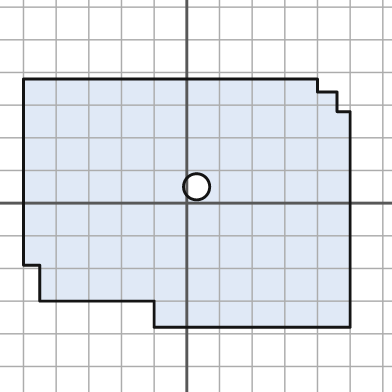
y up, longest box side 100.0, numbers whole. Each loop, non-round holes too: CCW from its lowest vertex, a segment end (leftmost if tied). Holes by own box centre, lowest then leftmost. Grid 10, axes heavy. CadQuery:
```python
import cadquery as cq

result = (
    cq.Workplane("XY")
    .moveTo(-10.0, -38.0)
    .lineTo(50.0, -38.0)
    .lineTo(50.0, 28.0)
    .lineTo(46.0, 28.0)
    .lineTo(46.0, 34.0)
    .lineTo(40.0, 34.0)
    .lineTo(40.0, 38.0)
    .lineTo(-50.0, 38.0)
    .lineTo(-50.0, -19.0)
    .lineTo(-45.0, -19.0)
    .lineTo(-45.0, -30.0)
    .lineTo(-10.0, -30.0)
    .close()
    .moveTo(3.0, 5.0)
    .circle(4.0)
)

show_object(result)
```